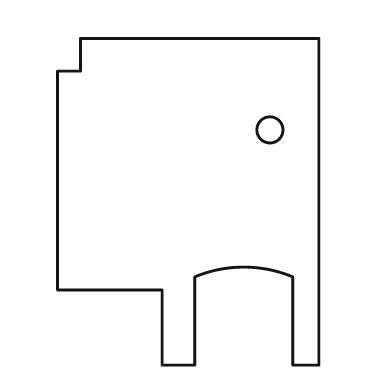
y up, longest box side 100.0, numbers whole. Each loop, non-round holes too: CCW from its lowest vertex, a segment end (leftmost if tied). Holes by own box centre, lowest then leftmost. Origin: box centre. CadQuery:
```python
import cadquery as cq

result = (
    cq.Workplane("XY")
    .moveTo(-8.0, -50.0)
    .lineTo(2.0, -50.0)
    .lineTo(2.0, -23.0)
    .threePointArc((17.0, -20.0), (32.0, -23.0))
    .lineTo(32.0, -50.0)
    .lineTo(40.0, -50.0)
    .lineTo(40.0, 50.0)
    .lineTo(-33.0, 50.0)
    .lineTo(-33.0, 40.0)
    .lineTo(-40.0, 40.0)
    .lineTo(-40.0, -27.0)
    .lineTo(-8.0, -27.0)
    .close()
    .moveTo(25.0, 22.0)
    .circle(4.0)
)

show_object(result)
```